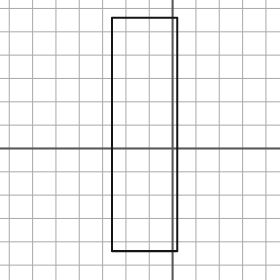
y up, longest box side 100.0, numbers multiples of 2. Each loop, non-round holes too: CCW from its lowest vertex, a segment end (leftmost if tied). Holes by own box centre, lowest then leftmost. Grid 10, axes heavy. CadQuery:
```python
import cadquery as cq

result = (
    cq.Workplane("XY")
    .moveTo(-26.0, -44.0)
    .lineTo(2.0, -44.0)
    .lineTo(2.0, 56.0)
    .lineTo(-26.0, 56.0)
    .close()
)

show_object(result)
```